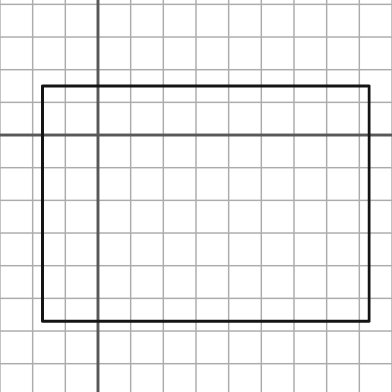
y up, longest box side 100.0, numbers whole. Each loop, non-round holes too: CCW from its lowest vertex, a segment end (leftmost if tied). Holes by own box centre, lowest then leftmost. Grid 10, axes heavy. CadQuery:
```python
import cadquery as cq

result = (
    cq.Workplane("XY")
    .moveTo(-17.0, -57.0)
    .lineTo(83.0, -57.0)
    .lineTo(83.0, 15.0)
    .lineTo(-17.0, 15.0)
    .close()
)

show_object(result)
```